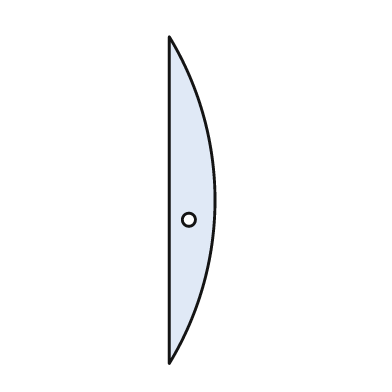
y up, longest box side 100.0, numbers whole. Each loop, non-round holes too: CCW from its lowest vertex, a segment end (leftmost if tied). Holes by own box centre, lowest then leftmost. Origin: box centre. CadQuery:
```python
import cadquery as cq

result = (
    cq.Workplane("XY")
    .moveTo(-7.0, -50.0)
    .threePointArc((7.0, 0.0), (-7.0, 50.0))
    .close()
    .moveTo(-1.0, -6.0)
    .circle(2.0)
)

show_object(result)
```